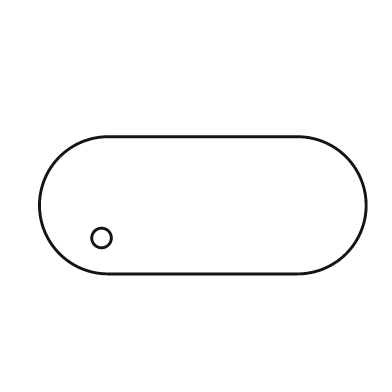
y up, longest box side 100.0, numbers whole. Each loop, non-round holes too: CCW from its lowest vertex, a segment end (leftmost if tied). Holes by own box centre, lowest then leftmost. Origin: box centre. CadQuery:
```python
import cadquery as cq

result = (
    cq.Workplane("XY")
    .moveTo(-29.0, -21.0)
    .lineTo(29.0, -21.0)
    .threePointArc((50.0, 0.0), (29.0, 21.0))
    .lineTo(-29.0, 21.0)
    .threePointArc((-50.0, 0.0), (-29.0, -21.0))
    .close()
    .moveTo(-31.0, -10.0)
    .circle(3.0)
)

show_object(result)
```